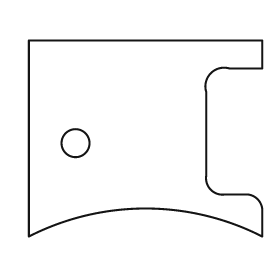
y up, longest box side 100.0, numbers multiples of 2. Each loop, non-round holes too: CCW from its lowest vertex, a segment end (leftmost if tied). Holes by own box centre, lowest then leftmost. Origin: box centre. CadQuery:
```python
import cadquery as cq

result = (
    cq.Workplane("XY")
    .moveTo(-50.0, -42.0)
    .threePointArc((0.0, -30.0), (50.0, -42.0))
    .lineTo(50.0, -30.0)
    .threePointArc((48.0, -26.0), (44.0, -24.0))
    .lineTo(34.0, -24.0)
    .threePointArc((28.0, -22.0), (26.0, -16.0))
    .lineTo(26.0, 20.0)
    .threePointArc((28.0, 28.0), (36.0, 30.0))
    .lineTo(50.0, 30.0)
    .lineTo(50.0, 42.0)
    .lineTo(-50.0, 42.0)
    .close()
    .moveTo(-30.0, -2.0)
    .circle(6.0)
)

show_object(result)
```